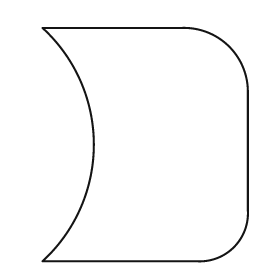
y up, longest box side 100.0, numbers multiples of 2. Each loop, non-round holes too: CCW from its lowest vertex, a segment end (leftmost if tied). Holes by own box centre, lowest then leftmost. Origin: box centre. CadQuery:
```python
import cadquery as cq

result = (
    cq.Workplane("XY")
    .moveTo(-44.0, -50.0)
    .lineTo(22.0, -50.0)
    .threePointArc((38.0, -44.0), (44.0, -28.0))
    .lineTo(44.0, 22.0)
    .threePointArc((36.0, 42.0), (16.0, 50.0))
    .lineTo(-44.0, 50.0)
    .threePointArc((-22.0, 0.0), (-44.0, -50.0))
    .close()
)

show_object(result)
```